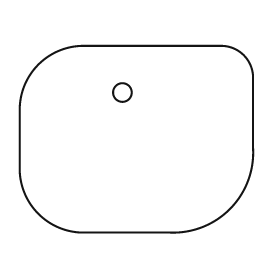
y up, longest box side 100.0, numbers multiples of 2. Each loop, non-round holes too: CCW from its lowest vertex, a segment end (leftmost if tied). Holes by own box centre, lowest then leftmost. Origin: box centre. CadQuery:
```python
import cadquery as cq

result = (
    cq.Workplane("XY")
    .moveTo(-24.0, -40.0)
    .lineTo(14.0, -40.0)
    .threePointArc((40.0, -30.0), (50.0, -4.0))
    .lineTo(50.0, 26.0)
    .threePointArc((46.0, 36.0), (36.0, 40.0))
    .lineTo(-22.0, 40.0)
    .threePointArc((-42.0, 32.0), (-50.0, 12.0))
    .lineTo(-50.0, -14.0)
    .threePointArc((-42.0, -32.0), (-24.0, -40.0))
    .close()
    .moveTo(-6.0, 20.0)
    .circle(4.0)
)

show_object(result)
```